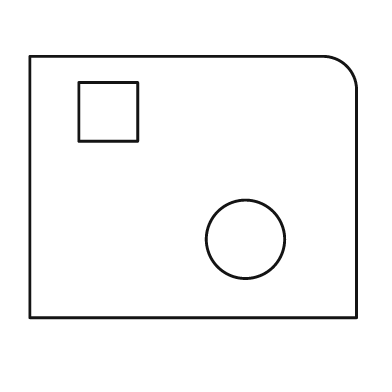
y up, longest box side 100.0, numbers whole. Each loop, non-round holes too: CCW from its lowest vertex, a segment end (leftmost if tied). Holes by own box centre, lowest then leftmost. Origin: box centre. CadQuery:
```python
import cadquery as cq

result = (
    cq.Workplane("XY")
    .moveTo(-50.0, -40.0)
    .lineTo(50.0, -40.0)
    .lineTo(50.0, 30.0)
    .threePointArc((47.0, 37.0), (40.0, 40.0))
    .lineTo(-50.0, 40.0)
    .close()
    .moveTo(16.0, -16.0)
    .circle(12.0)
    .moveTo(-35.0, 14.0)
    .lineTo(-17.0, 14.0)
    .lineTo(-17.0, 32.0)
    .lineTo(-35.0, 32.0)
    .close()
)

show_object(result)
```